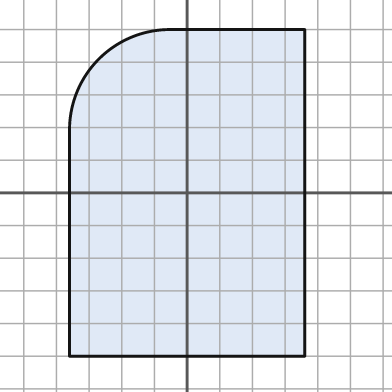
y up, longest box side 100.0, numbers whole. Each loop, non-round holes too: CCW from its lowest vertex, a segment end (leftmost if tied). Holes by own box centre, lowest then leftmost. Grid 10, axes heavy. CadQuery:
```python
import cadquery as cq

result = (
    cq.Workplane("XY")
    .moveTo(-36.0, -50.0)
    .lineTo(36.0, -50.0)
    .lineTo(36.0, 50.0)
    .lineTo(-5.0, 50.0)
    .threePointArc((-27.0, 41.0), (-36.0, 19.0))
    .close()
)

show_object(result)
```